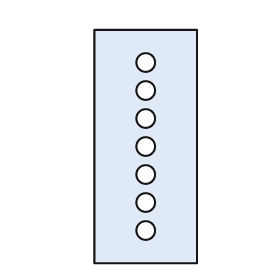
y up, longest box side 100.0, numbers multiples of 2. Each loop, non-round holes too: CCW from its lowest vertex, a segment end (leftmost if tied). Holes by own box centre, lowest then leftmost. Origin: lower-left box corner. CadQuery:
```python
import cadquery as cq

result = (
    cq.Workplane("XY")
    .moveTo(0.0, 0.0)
    .lineTo(44.0, 0.0)
    .lineTo(44.0, 100.0)
    .lineTo(0.0, 100.0)
    .close()
    .moveTo(22.0, 14.0)
    .circle(4.0)
    .moveTo(22.0, 26.0)
    .circle(4.0)
    .moveTo(22.0, 38.0)
    .circle(4.0)
    .moveTo(22.0, 50.0)
    .circle(4.0)
    .moveTo(22.0, 62.0)
    .circle(4.0)
    .moveTo(22.0, 74.0)
    .circle(4.0)
    .moveTo(22.0, 86.0)
    .circle(4.0)
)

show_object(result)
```